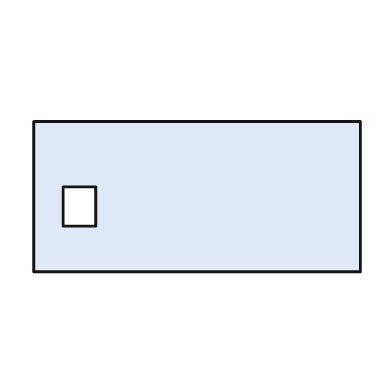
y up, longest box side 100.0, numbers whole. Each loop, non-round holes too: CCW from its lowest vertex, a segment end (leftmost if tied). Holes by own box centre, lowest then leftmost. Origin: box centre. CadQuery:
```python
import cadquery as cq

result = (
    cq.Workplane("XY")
    .moveTo(-50.0, -23.0)
    .lineTo(50.0, -23.0)
    .lineTo(50.0, 23.0)
    .lineTo(-50.0, 23.0)
    .close()
    .moveTo(-41.0, -9.0)
    .lineTo(-31.0, -9.0)
    .lineTo(-31.0, 3.0)
    .lineTo(-41.0, 3.0)
    .close()
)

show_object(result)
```